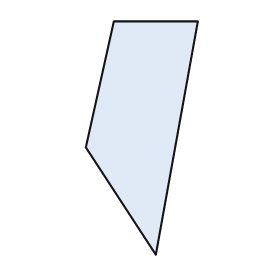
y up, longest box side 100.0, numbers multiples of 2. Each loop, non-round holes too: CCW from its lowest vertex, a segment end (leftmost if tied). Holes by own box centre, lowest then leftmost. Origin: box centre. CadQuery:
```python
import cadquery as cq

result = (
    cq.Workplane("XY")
    .moveTo(6.0, -50.0)
    .lineTo(24.0, 50.0)
    .lineTo(-12.0, 50.0)
    .lineTo(-24.0, -4.0)
    .close()
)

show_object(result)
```